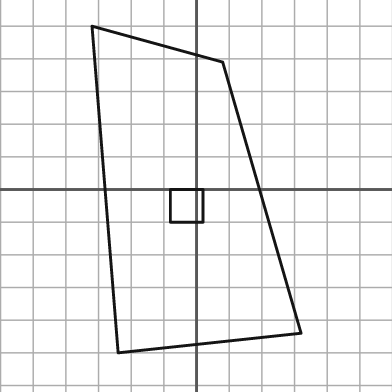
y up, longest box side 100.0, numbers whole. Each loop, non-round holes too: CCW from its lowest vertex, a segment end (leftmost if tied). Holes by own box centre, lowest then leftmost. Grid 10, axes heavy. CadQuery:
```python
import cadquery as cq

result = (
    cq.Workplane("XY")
    .moveTo(-24.0, -50.0)
    .lineTo(32.0, -44.0)
    .lineTo(8.0, 39.0)
    .lineTo(-32.0, 50.0)
    .close()
    .moveTo(-8.0, -10.0)
    .lineTo(2.0, -10.0)
    .lineTo(2.0, 0.0)
    .lineTo(-8.0, 0.0)
    .close()
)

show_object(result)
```